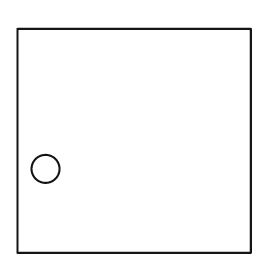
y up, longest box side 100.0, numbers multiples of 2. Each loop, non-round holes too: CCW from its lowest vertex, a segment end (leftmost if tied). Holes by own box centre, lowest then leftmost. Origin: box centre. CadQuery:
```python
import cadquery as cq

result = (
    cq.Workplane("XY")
    .moveTo(-50.0, -48.0)
    .lineTo(50.0, -48.0)
    .lineTo(50.0, 48.0)
    .lineTo(-50.0, 48.0)
    .close()
    .moveTo(-38.0, -12.0)
    .circle(6.0)
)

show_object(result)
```